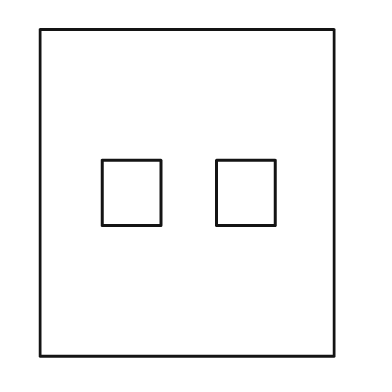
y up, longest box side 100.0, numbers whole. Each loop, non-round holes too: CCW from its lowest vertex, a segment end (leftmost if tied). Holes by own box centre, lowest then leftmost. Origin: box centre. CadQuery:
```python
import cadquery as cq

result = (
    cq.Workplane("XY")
    .moveTo(-45.0, -50.0)
    .lineTo(45.0, -50.0)
    .lineTo(45.0, 50.0)
    .lineTo(-45.0, 50.0)
    .close()
    .moveTo(-26.0, -10.0)
    .lineTo(-8.0, -10.0)
    .lineTo(-8.0, 10.0)
    .lineTo(-26.0, 10.0)
    .close()
    .moveTo(9.0, -10.0)
    .lineTo(27.0, -10.0)
    .lineTo(27.0, 10.0)
    .lineTo(9.0, 10.0)
    .close()
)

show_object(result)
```